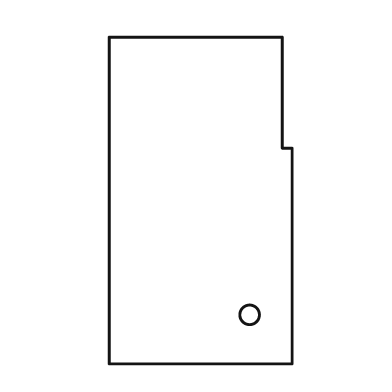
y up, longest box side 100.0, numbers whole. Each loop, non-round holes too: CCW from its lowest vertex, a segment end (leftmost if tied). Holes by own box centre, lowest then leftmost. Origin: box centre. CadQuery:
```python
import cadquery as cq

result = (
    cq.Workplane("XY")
    .moveTo(-28.0, -50.0)
    .lineTo(28.0, -50.0)
    .lineTo(28.0, 16.0)
    .lineTo(25.0, 16.0)
    .lineTo(25.0, 50.0)
    .lineTo(-28.0, 50.0)
    .close()
    .moveTo(15.0, -35.0)
    .circle(3.0)
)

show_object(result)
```